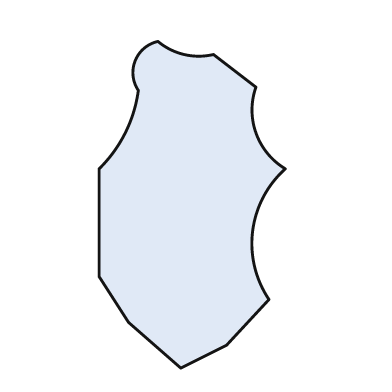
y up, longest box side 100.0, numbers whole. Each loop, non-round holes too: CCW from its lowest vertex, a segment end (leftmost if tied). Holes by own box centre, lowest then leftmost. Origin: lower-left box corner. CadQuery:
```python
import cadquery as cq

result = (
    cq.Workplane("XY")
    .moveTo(25.0, 0.0)
    .lineTo(39.0, 7.0)
    .lineTo(52.0, 21.0)
    .threePointArc((47.0, 42.0), (57.0, 61.0))
    .threePointArc((48.0, 72.0), (48.0, 86.0))
    .lineTo(35.0, 96.0)
    .threePointArc((26.0, 96.0), (18.0, 100.0))
    .threePointArc((11.0, 94.0), (12.0, 85.0))
    .threePointArc((8.0, 72.0), (0.0, 61.0))
    .lineTo(0.0, 28.0)
    .lineTo(9.0, 14.0)
    .close()
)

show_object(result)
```